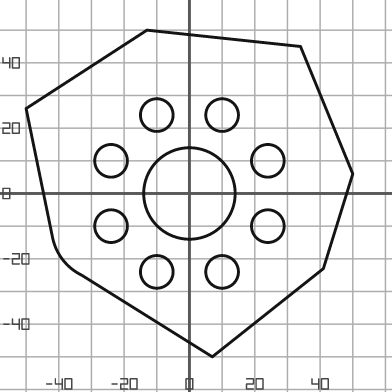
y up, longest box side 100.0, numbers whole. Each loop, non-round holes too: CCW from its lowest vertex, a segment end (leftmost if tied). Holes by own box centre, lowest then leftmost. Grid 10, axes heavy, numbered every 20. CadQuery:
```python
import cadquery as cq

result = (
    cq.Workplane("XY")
    .moveTo(7.0, -50.0)
    .lineTo(41.0, -23.0)
    .lineTo(50.0, 6.0)
    .lineTo(34.0, 45.0)
    .lineTo(-13.0, 50.0)
    .lineTo(-50.0, 26.0)
    .lineTo(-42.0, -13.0)
    .threePointArc((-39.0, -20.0), (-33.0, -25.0))
    .close()
    .moveTo(-10.0, -24.0)
    .circle(5.0)
    .moveTo(10.0, -24.0)
    .circle(5.0)
    .moveTo(-24.0, -10.0)
    .circle(5.0)
    .moveTo(24.0, -10.0)
    .circle(5.0)
    .moveTo(0.0, 0.0)
    .circle(14.0)
    .moveTo(-24.0, 10.0)
    .circle(5.0)
    .moveTo(24.0, 10.0)
    .circle(5.0)
    .moveTo(-10.0, 24.0)
    .circle(5.0)
    .moveTo(10.0, 24.0)
    .circle(5.0)
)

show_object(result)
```